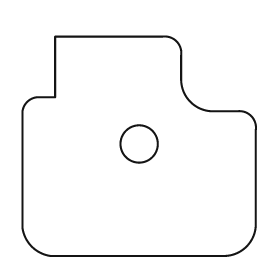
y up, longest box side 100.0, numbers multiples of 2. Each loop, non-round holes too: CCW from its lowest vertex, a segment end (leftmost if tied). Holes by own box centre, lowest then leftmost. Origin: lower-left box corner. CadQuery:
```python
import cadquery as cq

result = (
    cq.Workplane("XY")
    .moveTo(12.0, 0.0)
    .lineTo(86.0, 0.0)
    .threePointArc((96.0, 4.0), (100.0, 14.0))
    .lineTo(100.0, 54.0)
    .threePointArc((98.0, 60.0), (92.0, 62.0))
    .lineTo(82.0, 62.0)
    .threePointArc((72.0, 66.0), (68.0, 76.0))
    .lineTo(68.0, 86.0)
    .threePointArc((66.0, 92.0), (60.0, 94.0))
    .lineTo(14.0, 94.0)
    .lineTo(14.0, 68.0)
    .lineTo(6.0, 68.0)
    .threePointArc((2.0, 66.0), (0.0, 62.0))
    .lineTo(0.0, 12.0)
    .threePointArc((4.0, 4.0), (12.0, 0.0))
    .close()
    .moveTo(50.0, 48.0)
    .circle(8.0)
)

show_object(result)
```